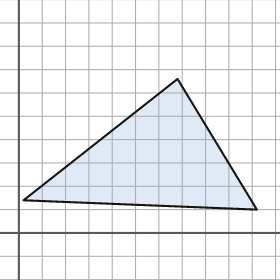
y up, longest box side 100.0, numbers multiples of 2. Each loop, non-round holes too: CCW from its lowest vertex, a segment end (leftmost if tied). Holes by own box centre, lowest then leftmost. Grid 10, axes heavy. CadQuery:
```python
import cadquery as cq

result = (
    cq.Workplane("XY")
    .moveTo(102.0, 10.0)
    .lineTo(68.0, 66.0)
    .lineTo(2.0, 14.0)
    .close()
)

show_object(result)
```